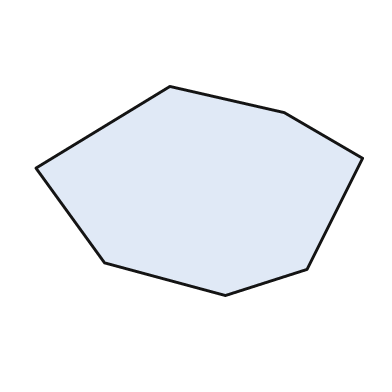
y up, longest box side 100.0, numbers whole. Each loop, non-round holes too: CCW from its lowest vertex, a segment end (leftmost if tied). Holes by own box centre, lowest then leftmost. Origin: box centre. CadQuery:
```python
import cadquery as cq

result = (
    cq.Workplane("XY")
    .moveTo(8.0, -32.0)
    .lineTo(33.0, -24.0)
    .lineTo(50.0, 10.0)
    .lineTo(26.0, 24.0)
    .lineTo(-9.0, 32.0)
    .lineTo(-50.0, 7.0)
    .lineTo(-29.0, -22.0)
    .close()
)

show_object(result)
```